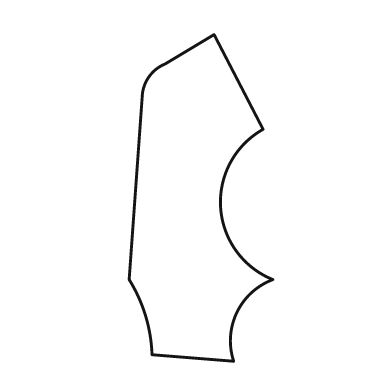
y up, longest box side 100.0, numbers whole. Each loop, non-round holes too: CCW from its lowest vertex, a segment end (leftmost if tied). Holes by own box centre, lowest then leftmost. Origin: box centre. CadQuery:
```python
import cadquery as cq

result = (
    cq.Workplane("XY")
    .moveTo(10.0, -50.0)
    .threePointArc((11.0, -35.0), (22.0, -25.0))
    .threePointArc((6.0, -3.0), (19.0, 21.0))
    .lineTo(4.0, 50.0)
    .lineTo(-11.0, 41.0)
    .threePointArc((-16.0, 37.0), (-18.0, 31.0))
    .lineTo(-22.0, -25.0)
    .threePointArc((-17.0, -36.0), (-15.0, -48.0))
    .close()
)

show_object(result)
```